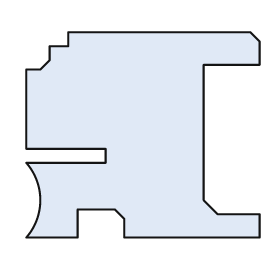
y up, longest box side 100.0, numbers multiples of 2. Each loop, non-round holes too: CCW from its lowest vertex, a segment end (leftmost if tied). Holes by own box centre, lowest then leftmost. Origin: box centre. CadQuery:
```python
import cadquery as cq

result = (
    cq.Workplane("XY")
    .moveTo(-50.0, -44.0)
    .lineTo(-28.0, -44.0)
    .lineTo(-28.0, -32.0)
    .lineTo(-12.0, -32.0)
    .lineTo(-8.0, -36.0)
    .lineTo(-8.0, -44.0)
    .lineTo(50.0, -44.0)
    .lineTo(50.0, -34.0)
    .lineTo(32.0, -34.0)
    .lineTo(26.0, -28.0)
    .lineTo(26.0, 30.0)
    .lineTo(50.0, 30.0)
    .lineTo(50.0, 40.0)
    .lineTo(46.0, 44.0)
    .lineTo(-32.0, 44.0)
    .lineTo(-32.0, 38.0)
    .lineTo(-40.0, 38.0)
    .lineTo(-40.0, 32.0)
    .lineTo(-44.0, 28.0)
    .lineTo(-50.0, 28.0)
    .lineTo(-50.0, -6.0)
    .lineTo(-16.0, -6.0)
    .lineTo(-16.0, -12.0)
    .lineTo(-50.0, -12.0)
    .threePointArc((-44.0, -28.0), (-50.0, -44.0))
    .close()
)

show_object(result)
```